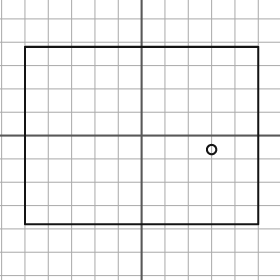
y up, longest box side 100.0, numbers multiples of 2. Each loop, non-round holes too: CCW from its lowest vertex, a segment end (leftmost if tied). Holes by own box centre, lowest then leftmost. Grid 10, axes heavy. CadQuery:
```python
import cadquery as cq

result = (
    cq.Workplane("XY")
    .moveTo(-50.0, -38.0)
    .lineTo(50.0, -38.0)
    .lineTo(50.0, 38.0)
    .lineTo(-50.0, 38.0)
    .close()
    .moveTo(30.0, -6.0)
    .circle(2.0)
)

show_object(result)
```